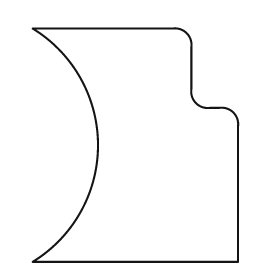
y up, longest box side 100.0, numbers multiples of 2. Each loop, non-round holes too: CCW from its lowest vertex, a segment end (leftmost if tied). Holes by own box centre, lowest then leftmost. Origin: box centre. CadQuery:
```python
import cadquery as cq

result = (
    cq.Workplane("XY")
    .moveTo(-44.0, -50.0)
    .lineTo(44.0, -50.0)
    .lineTo(44.0, 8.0)
    .threePointArc((42.0, 14.0), (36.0, 16.0))
    .lineTo(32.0, 16.0)
    .threePointArc((26.0, 18.0), (24.0, 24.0))
    .lineTo(24.0, 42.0)
    .threePointArc((22.0, 48.0), (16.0, 50.0))
    .lineTo(-44.0, 50.0)
    .threePointArc((-16.0, 0.0), (-44.0, -50.0))
    .close()
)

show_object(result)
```